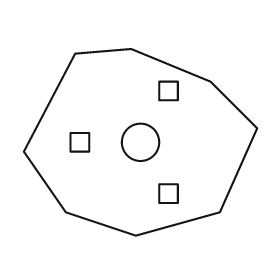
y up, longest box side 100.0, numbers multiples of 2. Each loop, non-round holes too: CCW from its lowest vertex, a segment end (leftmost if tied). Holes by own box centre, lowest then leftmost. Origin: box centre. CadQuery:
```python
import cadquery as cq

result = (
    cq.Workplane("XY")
    .moveTo(-2.0, -40.0)
    .lineTo(34.0, -30.0)
    .lineTo(50.0, 6.0)
    .lineTo(30.0, 26.0)
    .lineTo(-4.0, 40.0)
    .lineTo(-28.0, 38.0)
    .lineTo(-50.0, -4.0)
    .lineTo(-32.0, -30.0)
    .close()
    .moveTo(8.0, -26.0)
    .lineTo(16.0, -26.0)
    .lineTo(16.0, -18.0)
    .lineTo(8.0, -18.0)
    .close()
    .moveTo(-30.0, -4.0)
    .lineTo(-22.0, -4.0)
    .lineTo(-22.0, 4.0)
    .lineTo(-30.0, 4.0)
    .close()
    .moveTo(0.0, 0.0)
    .circle(8.0)
    .moveTo(8.0, 18.0)
    .lineTo(16.0, 18.0)
    .lineTo(16.0, 26.0)
    .lineTo(8.0, 26.0)
    .close()
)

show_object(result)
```